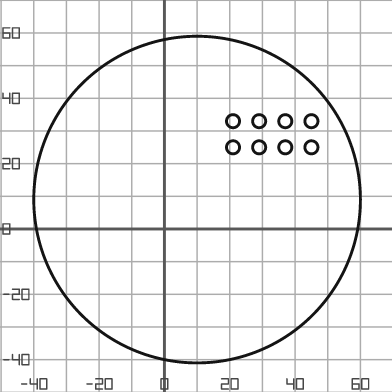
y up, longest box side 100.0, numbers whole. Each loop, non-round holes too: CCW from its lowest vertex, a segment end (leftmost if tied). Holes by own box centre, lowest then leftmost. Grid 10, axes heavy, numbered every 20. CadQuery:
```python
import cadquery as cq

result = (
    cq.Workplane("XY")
    .moveTo(10.0, 9.0)
    .circle(50.0)
    .moveTo(21.0, 25.0)
    .circle(2.0)
    .moveTo(29.0, 25.0)
    .circle(2.0)
    .moveTo(37.0, 25.0)
    .circle(2.0)
    .moveTo(45.0, 25.0)
    .circle(2.0)
    .moveTo(21.0, 33.0)
    .circle(2.0)
    .moveTo(29.0, 33.0)
    .circle(2.0)
    .moveTo(37.0, 33.0)
    .circle(2.0)
    .moveTo(45.0, 33.0)
    .circle(2.0)
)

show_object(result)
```